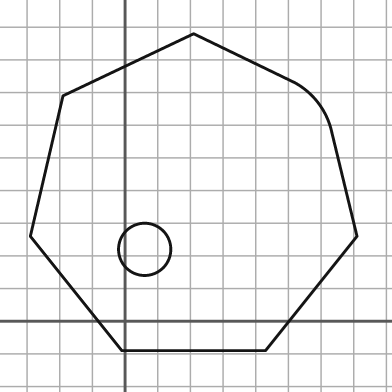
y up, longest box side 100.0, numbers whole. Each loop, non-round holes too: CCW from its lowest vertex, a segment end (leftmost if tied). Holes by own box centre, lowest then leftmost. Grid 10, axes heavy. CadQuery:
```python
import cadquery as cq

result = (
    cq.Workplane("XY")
    .moveTo(-1.0, -9.0)
    .lineTo(43.0, -9.0)
    .lineTo(71.0, 26.0)
    .lineTo(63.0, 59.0)
    .threePointArc((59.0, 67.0), (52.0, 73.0))
    .lineTo(21.0, 88.0)
    .lineTo(-19.0, 69.0)
    .lineTo(-29.0, 26.0)
    .close()
    .moveTo(6.0, 22.0)
    .circle(8.0)
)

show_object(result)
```